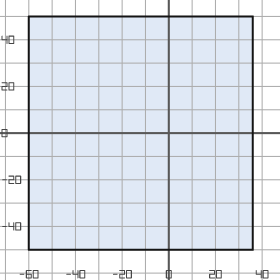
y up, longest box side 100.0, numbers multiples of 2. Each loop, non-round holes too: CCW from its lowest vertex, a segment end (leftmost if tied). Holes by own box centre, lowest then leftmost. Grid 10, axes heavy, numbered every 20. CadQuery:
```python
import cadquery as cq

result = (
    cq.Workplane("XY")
    .moveTo(-60.0, -50.0)
    .lineTo(36.0, -50.0)
    .lineTo(36.0, 50.0)
    .lineTo(-60.0, 50.0)
    .close()
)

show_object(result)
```